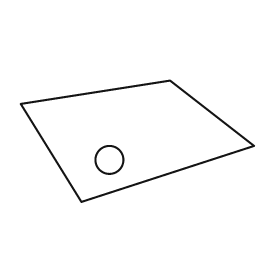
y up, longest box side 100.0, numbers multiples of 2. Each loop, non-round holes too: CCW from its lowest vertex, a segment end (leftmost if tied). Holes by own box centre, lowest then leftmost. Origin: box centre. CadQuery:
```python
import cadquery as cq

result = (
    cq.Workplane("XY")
    .moveTo(-24.0, -26.0)
    .lineTo(50.0, -2.0)
    .lineTo(14.0, 26.0)
    .lineTo(-50.0, 16.0)
    .close()
    .moveTo(-12.0, -8.0)
    .circle(6.0)
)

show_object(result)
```